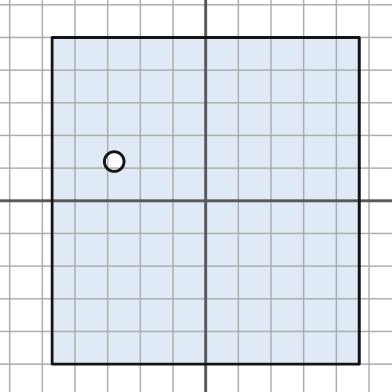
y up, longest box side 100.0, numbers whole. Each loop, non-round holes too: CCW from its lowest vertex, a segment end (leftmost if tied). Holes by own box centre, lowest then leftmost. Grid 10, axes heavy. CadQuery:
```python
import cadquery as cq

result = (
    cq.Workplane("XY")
    .moveTo(-47.0, -50.0)
    .lineTo(47.0, -50.0)
    .lineTo(47.0, 50.0)
    .lineTo(-47.0, 50.0)
    .close()
    .moveTo(-28.0, 12.0)
    .circle(3.0)
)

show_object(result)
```